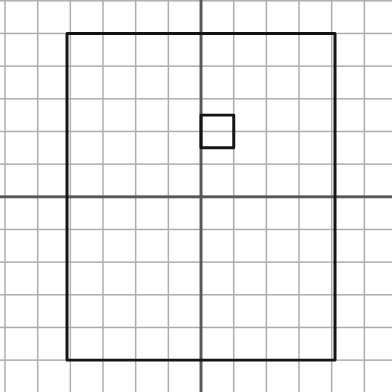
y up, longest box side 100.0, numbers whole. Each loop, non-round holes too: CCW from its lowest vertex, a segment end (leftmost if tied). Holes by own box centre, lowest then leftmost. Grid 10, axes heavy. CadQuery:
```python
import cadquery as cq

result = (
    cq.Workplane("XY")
    .moveTo(-41.0, -50.0)
    .lineTo(41.0, -50.0)
    .lineTo(41.0, 50.0)
    .lineTo(-41.0, 50.0)
    .close()
    .moveTo(0.0, 15.0)
    .lineTo(10.0, 15.0)
    .lineTo(10.0, 25.0)
    .lineTo(0.0, 25.0)
    .close()
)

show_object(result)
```